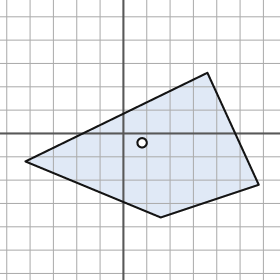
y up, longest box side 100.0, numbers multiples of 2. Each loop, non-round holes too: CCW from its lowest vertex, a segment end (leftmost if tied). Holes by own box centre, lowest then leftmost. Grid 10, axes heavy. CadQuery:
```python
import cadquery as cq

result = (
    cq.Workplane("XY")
    .moveTo(16.0, -36.0)
    .lineTo(58.0, -22.0)
    .lineTo(36.0, 26.0)
    .lineTo(-42.0, -12.0)
    .close()
    .moveTo(8.0, -4.0)
    .circle(2.0)
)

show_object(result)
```